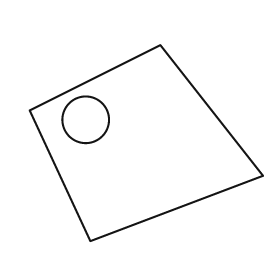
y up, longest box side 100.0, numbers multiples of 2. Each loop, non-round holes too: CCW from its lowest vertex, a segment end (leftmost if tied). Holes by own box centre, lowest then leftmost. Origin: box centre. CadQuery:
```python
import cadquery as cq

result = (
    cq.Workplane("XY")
    .moveTo(-24.0, -42.0)
    .lineTo(50.0, -14.0)
    .lineTo(6.0, 42.0)
    .lineTo(-50.0, 14.0)
    .close()
    .moveTo(-26.0, 10.0)
    .circle(10.0)
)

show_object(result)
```